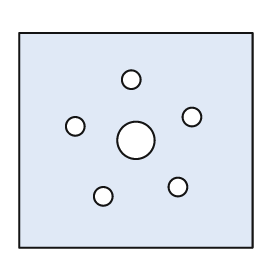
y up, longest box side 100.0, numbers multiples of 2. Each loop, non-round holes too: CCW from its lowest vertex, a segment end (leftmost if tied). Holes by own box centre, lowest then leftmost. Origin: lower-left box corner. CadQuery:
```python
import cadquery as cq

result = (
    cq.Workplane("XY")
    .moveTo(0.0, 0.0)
    .lineTo(100.0, 0.0)
    .lineTo(100.0, 92.0)
    .lineTo(0.0, 92.0)
    .close()
    .moveTo(36.0, 22.0)
    .circle(4.0)
    .moveTo(68.0, 26.0)
    .circle(4.0)
    .moveTo(50.0, 46.0)
    .circle(8.0)
    .moveTo(24.0, 52.0)
    .circle(4.0)
    .moveTo(74.0, 56.0)
    .circle(4.0)
    .moveTo(48.0, 72.0)
    .circle(4.0)
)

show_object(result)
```